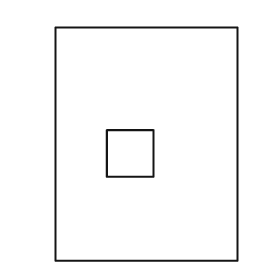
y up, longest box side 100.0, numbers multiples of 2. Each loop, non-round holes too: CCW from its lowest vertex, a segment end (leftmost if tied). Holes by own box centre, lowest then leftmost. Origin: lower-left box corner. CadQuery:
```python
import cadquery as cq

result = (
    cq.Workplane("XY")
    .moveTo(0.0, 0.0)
    .lineTo(78.0, 0.0)
    .lineTo(78.0, 100.0)
    .lineTo(0.0, 100.0)
    .close()
    .moveTo(22.0, 36.0)
    .lineTo(42.0, 36.0)
    .lineTo(42.0, 56.0)
    .lineTo(22.0, 56.0)
    .close()
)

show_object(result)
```